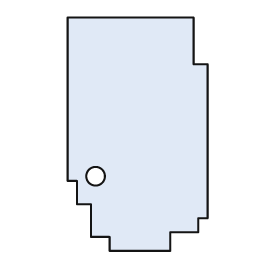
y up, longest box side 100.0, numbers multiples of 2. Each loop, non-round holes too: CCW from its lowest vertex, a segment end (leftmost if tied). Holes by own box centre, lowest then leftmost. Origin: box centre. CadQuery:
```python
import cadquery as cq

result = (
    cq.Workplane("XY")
    .moveTo(-12.0, -50.0)
    .lineTo(14.0, -50.0)
    .lineTo(14.0, -42.0)
    .lineTo(26.0, -42.0)
    .lineTo(26.0, -36.0)
    .lineTo(30.0, -36.0)
    .lineTo(30.0, 30.0)
    .lineTo(24.0, 30.0)
    .lineTo(24.0, 50.0)
    .lineTo(-30.0, 50.0)
    .lineTo(-30.0, -20.0)
    .lineTo(-26.0, -20.0)
    .lineTo(-26.0, -30.0)
    .lineTo(-20.0, -30.0)
    .lineTo(-20.0, -44.0)
    .lineTo(-12.0, -44.0)
    .close()
    .moveTo(-18.0, -18.0)
    .circle(4.0)
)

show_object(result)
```